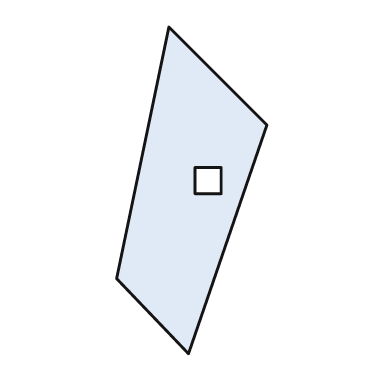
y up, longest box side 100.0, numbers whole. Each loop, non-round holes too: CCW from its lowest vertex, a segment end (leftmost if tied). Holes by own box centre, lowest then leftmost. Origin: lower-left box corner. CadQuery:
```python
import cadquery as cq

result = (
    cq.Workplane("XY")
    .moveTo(22.0, 0.0)
    .lineTo(46.0, 70.0)
    .lineTo(16.0, 100.0)
    .lineTo(0.0, 23.0)
    .close()
    .moveTo(24.0, 49.0)
    .lineTo(32.0, 49.0)
    .lineTo(32.0, 57.0)
    .lineTo(24.0, 57.0)
    .close()
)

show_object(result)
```